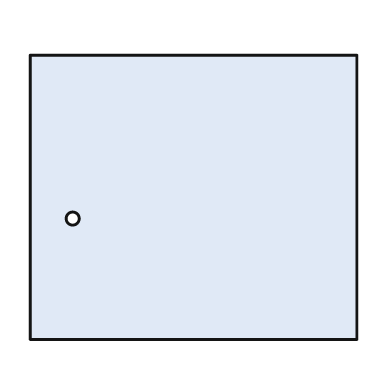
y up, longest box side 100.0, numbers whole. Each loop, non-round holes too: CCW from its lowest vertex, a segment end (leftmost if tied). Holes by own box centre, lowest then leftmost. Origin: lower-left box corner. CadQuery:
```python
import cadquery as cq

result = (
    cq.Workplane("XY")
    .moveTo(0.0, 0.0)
    .lineTo(100.0, 0.0)
    .lineTo(100.0, 87.0)
    .lineTo(0.0, 87.0)
    .close()
    .moveTo(13.0, 37.0)
    .circle(2.0)
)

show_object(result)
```